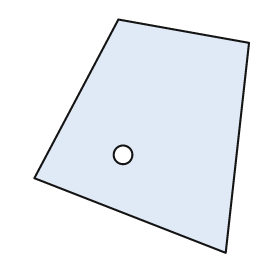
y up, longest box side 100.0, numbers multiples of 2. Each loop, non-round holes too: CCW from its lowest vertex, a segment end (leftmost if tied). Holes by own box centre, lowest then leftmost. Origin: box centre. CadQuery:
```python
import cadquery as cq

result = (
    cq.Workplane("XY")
    .moveTo(36.0, -50.0)
    .lineTo(46.0, 40.0)
    .lineTo(-10.0, 50.0)
    .lineTo(-46.0, -18.0)
    .close()
    .moveTo(-8.0, -8.0)
    .circle(4.0)
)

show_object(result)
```